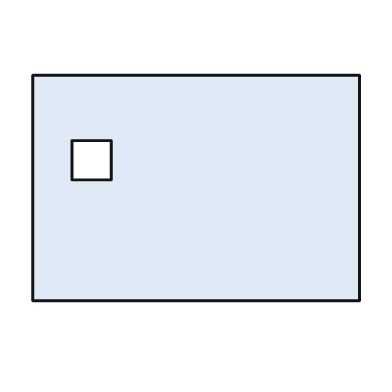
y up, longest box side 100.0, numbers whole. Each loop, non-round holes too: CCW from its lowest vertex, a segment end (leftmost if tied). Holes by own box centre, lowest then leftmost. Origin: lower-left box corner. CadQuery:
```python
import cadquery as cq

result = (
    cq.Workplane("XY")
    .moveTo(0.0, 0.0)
    .lineTo(100.0, 0.0)
    .lineTo(100.0, 69.0)
    .lineTo(0.0, 69.0)
    .close()
    .moveTo(12.0, 37.0)
    .lineTo(24.0, 37.0)
    .lineTo(24.0, 49.0)
    .lineTo(12.0, 49.0)
    .close()
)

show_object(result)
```